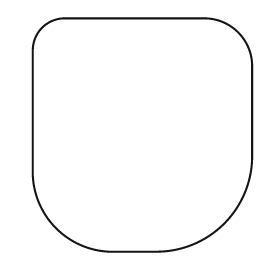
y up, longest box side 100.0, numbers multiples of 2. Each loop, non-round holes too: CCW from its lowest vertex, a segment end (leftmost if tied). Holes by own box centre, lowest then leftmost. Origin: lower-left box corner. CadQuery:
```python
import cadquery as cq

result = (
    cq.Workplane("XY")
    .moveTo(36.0, 0.0)
    .lineTo(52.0, 0.0)
    .threePointArc((82.0, 12.0), (94.0, 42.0))
    .lineTo(94.0, 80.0)
    .threePointArc((88.0, 94.0), (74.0, 100.0))
    .lineTo(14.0, 100.0)
    .threePointArc((4.0, 96.0), (0.0, 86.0))
    .lineTo(0.0, 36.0)
    .threePointArc((10.0, 10.0), (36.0, 0.0))
    .close()
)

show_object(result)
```